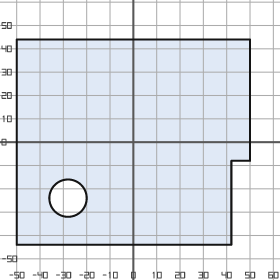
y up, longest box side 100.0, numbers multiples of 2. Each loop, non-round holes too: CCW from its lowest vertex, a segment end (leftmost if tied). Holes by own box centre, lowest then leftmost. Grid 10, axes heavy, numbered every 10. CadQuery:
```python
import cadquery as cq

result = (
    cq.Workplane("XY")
    .moveTo(-50.0, -44.0)
    .lineTo(42.0, -44.0)
    .lineTo(42.0, -8.0)
    .lineTo(50.0, -8.0)
    .lineTo(50.0, 44.0)
    .lineTo(-50.0, 44.0)
    .close()
    .moveTo(-28.0, -24.0)
    .circle(8.0)
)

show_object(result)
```